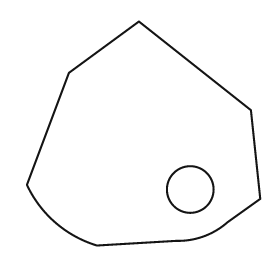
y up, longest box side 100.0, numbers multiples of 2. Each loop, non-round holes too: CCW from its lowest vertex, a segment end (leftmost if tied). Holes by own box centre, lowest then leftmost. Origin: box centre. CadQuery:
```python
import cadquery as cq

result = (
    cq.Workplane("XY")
    .moveTo(-20.0, -48.0)
    .lineTo(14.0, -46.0)
    .threePointArc((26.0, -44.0), (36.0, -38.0))
    .lineTo(50.0, -28.0)
    .lineTo(46.0, 10.0)
    .lineTo(-2.0, 48.0)
    .lineTo(-32.0, 26.0)
    .lineTo(-50.0, -22.0)
    .threePointArc((-38.0, -38.0), (-20.0, -48.0))
    .close()
    .moveTo(20.0, -24.0)
    .circle(10.0)
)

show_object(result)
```